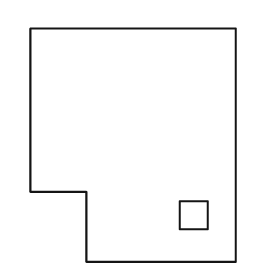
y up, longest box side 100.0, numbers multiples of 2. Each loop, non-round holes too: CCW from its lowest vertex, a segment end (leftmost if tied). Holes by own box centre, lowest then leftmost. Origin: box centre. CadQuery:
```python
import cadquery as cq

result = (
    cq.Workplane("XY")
    .moveTo(-20.0, -50.0)
    .lineTo(44.0, -50.0)
    .lineTo(44.0, 50.0)
    .lineTo(-44.0, 50.0)
    .lineTo(-44.0, -20.0)
    .lineTo(-20.0, -20.0)
    .close()
    .moveTo(20.0, -36.0)
    .lineTo(32.0, -36.0)
    .lineTo(32.0, -24.0)
    .lineTo(20.0, -24.0)
    .close()
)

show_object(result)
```